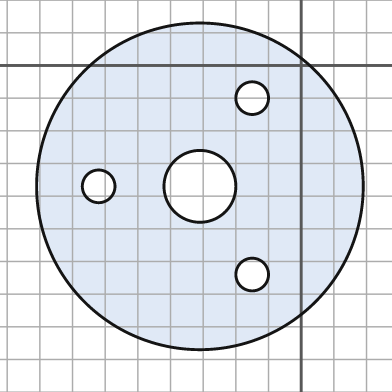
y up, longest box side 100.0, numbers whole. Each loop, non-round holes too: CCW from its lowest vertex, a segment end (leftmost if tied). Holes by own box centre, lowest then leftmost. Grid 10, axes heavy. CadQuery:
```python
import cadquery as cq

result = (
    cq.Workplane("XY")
    .moveTo(-31.0, -37.0)
    .circle(50.0)
    .moveTo(-15.0, -64.0)
    .circle(5.0)
    .moveTo(-62.0, -37.0)
    .circle(5.0)
    .moveTo(-31.0, -37.0)
    .circle(11.0)
    .moveTo(-15.0, -10.0)
    .circle(5.0)
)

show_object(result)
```